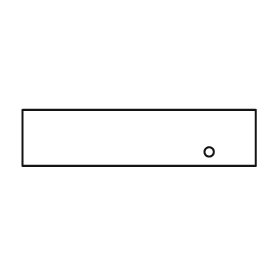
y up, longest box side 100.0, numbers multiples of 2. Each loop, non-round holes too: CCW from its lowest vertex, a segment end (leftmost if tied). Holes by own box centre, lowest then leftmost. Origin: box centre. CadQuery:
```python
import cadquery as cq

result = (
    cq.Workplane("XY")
    .moveTo(-50.0, -12.0)
    .lineTo(50.0, -12.0)
    .lineTo(50.0, 12.0)
    .lineTo(-50.0, 12.0)
    .close()
    .moveTo(30.0, -6.0)
    .circle(2.0)
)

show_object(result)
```